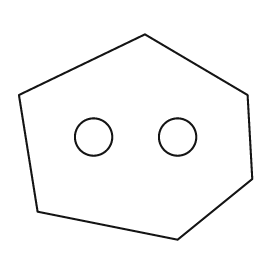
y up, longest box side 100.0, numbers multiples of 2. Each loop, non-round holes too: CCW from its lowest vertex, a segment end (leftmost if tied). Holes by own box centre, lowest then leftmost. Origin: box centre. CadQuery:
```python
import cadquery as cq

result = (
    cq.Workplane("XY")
    .moveTo(18.0, -44.0)
    .lineTo(50.0, -18.0)
    .lineTo(48.0, 18.0)
    .lineTo(4.0, 44.0)
    .lineTo(-50.0, 18.0)
    .lineTo(-42.0, -32.0)
    .close()
    .moveTo(-18.0, 0.0)
    .circle(8.0)
    .moveTo(18.0, 0.0)
    .circle(8.0)
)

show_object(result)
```